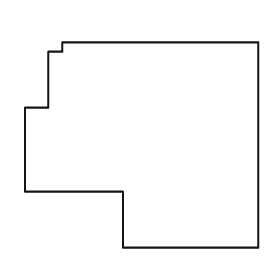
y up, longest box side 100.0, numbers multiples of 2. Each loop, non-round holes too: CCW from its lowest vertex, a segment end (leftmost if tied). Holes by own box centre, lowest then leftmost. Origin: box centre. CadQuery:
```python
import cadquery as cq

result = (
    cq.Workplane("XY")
    .moveTo(-8.0, -44.0)
    .lineTo(50.0, -44.0)
    .lineTo(50.0, 44.0)
    .lineTo(-34.0, 44.0)
    .lineTo(-34.0, 40.0)
    .lineTo(-40.0, 40.0)
    .lineTo(-40.0, 16.0)
    .lineTo(-50.0, 16.0)
    .lineTo(-50.0, -20.0)
    .lineTo(-8.0, -20.0)
    .close()
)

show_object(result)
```